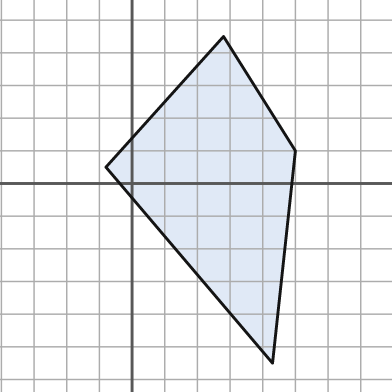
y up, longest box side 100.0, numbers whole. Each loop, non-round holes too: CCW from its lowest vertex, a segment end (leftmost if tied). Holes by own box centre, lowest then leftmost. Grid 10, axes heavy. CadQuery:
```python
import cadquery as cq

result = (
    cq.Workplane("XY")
    .moveTo(43.0, -55.0)
    .lineTo(50.0, 10.0)
    .lineTo(28.0, 45.0)
    .lineTo(-8.0, 5.0)
    .close()
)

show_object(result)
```